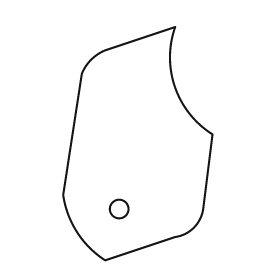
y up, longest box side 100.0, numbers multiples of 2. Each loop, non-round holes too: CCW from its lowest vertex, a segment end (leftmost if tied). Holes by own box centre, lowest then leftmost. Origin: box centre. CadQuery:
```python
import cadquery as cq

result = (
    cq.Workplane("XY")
    .moveTo(-14.0, -50.0)
    .lineTo(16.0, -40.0)
    .threePointArc((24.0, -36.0), (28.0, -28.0))
    .lineTo(32.0, 4.0)
    .threePointArc((16.0, 24.0), (16.0, 50.0))
    .lineTo(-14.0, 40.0)
    .threePointArc((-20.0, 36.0), (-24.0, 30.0))
    .lineTo(-32.0, -22.0)
    .threePointArc((-26.0, -38.0), (-14.0, -50.0))
    .close()
    .moveTo(-8.0, -28.0)
    .circle(4.0)
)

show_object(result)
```